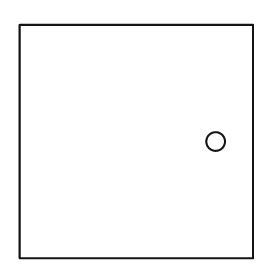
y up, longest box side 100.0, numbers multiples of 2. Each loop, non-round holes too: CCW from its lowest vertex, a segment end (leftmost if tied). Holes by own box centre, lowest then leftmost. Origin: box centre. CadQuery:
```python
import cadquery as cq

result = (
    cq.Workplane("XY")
    .moveTo(-50.0, -50.0)
    .lineTo(50.0, -50.0)
    .lineTo(50.0, 50.0)
    .lineTo(-50.0, 50.0)
    .close()
    .moveTo(34.0, 0.0)
    .circle(4.0)
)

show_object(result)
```